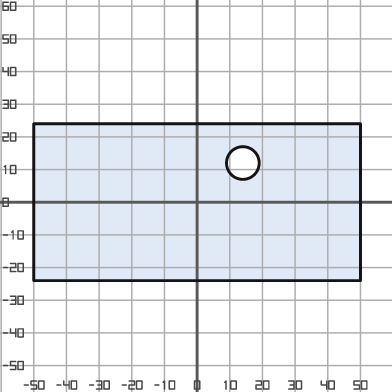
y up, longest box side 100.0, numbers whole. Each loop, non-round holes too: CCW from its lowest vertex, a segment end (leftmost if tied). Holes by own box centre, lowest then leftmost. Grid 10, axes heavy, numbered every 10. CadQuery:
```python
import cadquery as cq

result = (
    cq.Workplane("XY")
    .moveTo(-50.0, -24.0)
    .lineTo(50.0, -24.0)
    .lineTo(50.0, 24.0)
    .lineTo(-50.0, 24.0)
    .close()
    .moveTo(14.0, 12.0)
    .circle(5.0)
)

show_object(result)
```